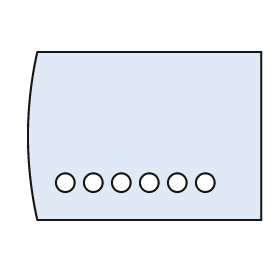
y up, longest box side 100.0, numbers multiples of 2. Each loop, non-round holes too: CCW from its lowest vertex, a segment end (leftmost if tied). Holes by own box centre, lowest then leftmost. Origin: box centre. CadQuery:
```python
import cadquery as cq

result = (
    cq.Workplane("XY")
    .moveTo(-46.0, -36.0)
    .lineTo(50.0, -36.0)
    .lineTo(50.0, 36.0)
    .lineTo(-46.0, 36.0)
    .threePointArc((-50.0, 0.0), (-46.0, -36.0))
    .close()
    .moveTo(-34.0, -20.0)
    .circle(4.0)
    .moveTo(-22.0, -20.0)
    .circle(4.0)
    .moveTo(-10.0, -20.0)
    .circle(4.0)
    .moveTo(2.0, -20.0)
    .circle(4.0)
    .moveTo(14.0, -20.0)
    .circle(4.0)
    .moveTo(26.0, -20.0)
    .circle(4.0)
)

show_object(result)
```